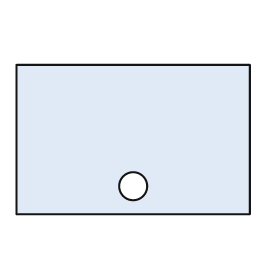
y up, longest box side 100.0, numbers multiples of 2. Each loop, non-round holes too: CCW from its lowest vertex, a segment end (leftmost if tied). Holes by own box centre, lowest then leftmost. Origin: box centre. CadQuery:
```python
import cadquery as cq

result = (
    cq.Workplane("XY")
    .moveTo(-50.0, -32.0)
    .lineTo(50.0, -32.0)
    .lineTo(50.0, 32.0)
    .lineTo(-50.0, 32.0)
    .close()
    .moveTo(0.0, -20.0)
    .circle(6.0)
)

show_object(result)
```